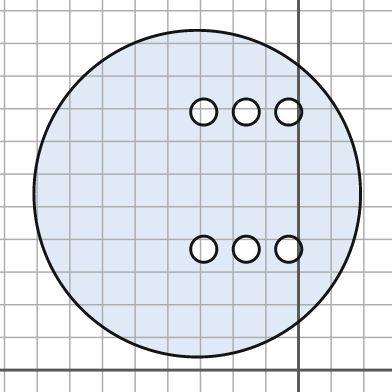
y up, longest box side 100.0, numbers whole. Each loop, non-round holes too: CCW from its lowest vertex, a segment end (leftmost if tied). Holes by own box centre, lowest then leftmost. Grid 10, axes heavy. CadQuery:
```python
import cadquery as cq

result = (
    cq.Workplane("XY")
    .moveTo(-31.0, 54.0)
    .circle(50.0)
    .moveTo(-29.0, 37.0)
    .circle(4.0)
    .moveTo(-16.0, 37.0)
    .circle(4.0)
    .moveTo(-3.0, 37.0)
    .circle(4.0)
    .moveTo(-29.0, 79.0)
    .circle(4.0)
    .moveTo(-16.0, 79.0)
    .circle(4.0)
    .moveTo(-3.0, 79.0)
    .circle(4.0)
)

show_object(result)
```